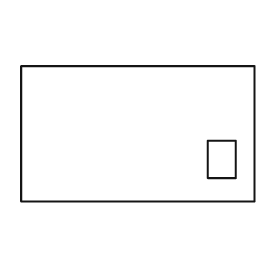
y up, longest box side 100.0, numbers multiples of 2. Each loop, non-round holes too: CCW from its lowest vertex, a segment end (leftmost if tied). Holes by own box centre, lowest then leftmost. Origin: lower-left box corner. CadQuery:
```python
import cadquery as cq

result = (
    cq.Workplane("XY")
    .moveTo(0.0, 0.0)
    .lineTo(100.0, 0.0)
    .lineTo(100.0, 58.0)
    .lineTo(0.0, 58.0)
    .close()
    .moveTo(80.0, 10.0)
    .lineTo(92.0, 10.0)
    .lineTo(92.0, 26.0)
    .lineTo(80.0, 26.0)
    .close()
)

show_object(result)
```